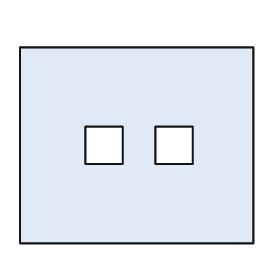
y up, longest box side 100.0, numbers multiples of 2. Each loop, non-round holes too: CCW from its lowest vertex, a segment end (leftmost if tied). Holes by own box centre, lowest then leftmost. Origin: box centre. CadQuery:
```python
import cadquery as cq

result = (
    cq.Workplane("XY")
    .moveTo(-50.0, -42.0)
    .lineTo(50.0, -42.0)
    .lineTo(50.0, 42.0)
    .lineTo(-50.0, 42.0)
    .close()
    .moveTo(-22.0, -8.0)
    .lineTo(-6.0, -8.0)
    .lineTo(-6.0, 8.0)
    .lineTo(-22.0, 8.0)
    .close()
    .moveTo(8.0, -8.0)
    .lineTo(24.0, -8.0)
    .lineTo(24.0, 8.0)
    .lineTo(8.0, 8.0)
    .close()
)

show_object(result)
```